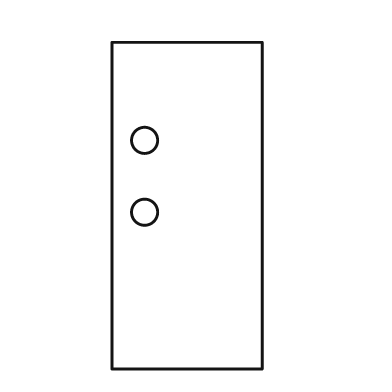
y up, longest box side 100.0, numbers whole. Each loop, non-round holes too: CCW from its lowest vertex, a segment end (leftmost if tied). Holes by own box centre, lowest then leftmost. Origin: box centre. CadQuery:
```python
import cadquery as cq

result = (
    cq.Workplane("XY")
    .moveTo(-23.0, -50.0)
    .lineTo(23.0, -50.0)
    .lineTo(23.0, 50.0)
    .lineTo(-23.0, 50.0)
    .close()
    .moveTo(-13.0, -2.0)
    .circle(4.0)
    .moveTo(-13.0, 20.0)
    .circle(4.0)
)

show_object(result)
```